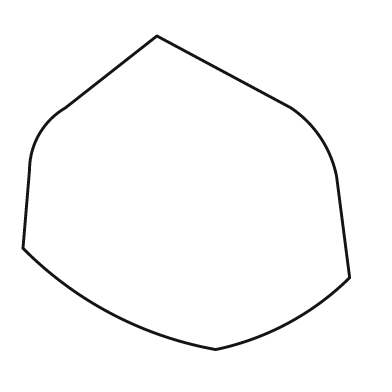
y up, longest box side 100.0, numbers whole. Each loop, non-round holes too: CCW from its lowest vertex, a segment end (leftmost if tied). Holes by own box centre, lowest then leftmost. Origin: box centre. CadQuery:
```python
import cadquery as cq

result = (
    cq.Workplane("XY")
    .moveTo(9.0, -48.0)
    .threePointArc((31.0, -40.0), (50.0, -26.0))
    .lineTo(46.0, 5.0)
    .threePointArc((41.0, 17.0), (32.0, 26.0))
    .lineTo(-9.0, 48.0)
    .lineTo(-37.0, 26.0)
    .threePointArc((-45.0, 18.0), (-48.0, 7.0))
    .lineTo(-50.0, -17.0)
    .threePointArc((-23.0, -37.0), (9.0, -48.0))
    .close()
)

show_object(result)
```